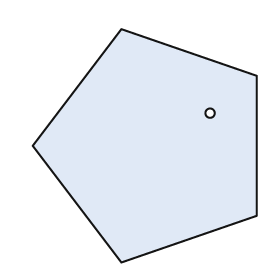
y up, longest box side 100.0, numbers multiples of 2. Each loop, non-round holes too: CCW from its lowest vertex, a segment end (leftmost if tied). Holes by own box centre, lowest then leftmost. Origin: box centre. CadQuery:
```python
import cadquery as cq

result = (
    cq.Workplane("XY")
    .moveTo(-10.0, -50.0)
    .lineTo(48.0, -30.0)
    .lineTo(48.0, 30.0)
    .lineTo(-10.0, 50.0)
    .lineTo(-48.0, 0.0)
    .close()
    .moveTo(28.0, 14.0)
    .circle(2.0)
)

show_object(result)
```